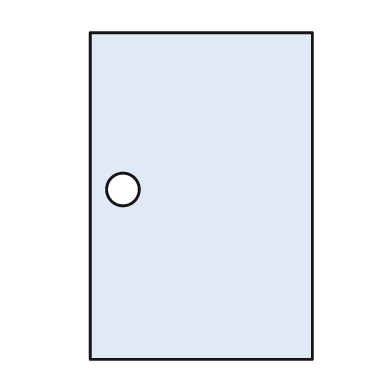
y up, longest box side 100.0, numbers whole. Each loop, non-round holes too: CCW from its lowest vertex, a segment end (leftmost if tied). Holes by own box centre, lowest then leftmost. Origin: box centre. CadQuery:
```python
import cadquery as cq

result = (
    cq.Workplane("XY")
    .moveTo(-34.0, -50.0)
    .lineTo(34.0, -50.0)
    .lineTo(34.0, 50.0)
    .lineTo(-34.0, 50.0)
    .close()
    .moveTo(-24.0, 2.0)
    .circle(5.0)
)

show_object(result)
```